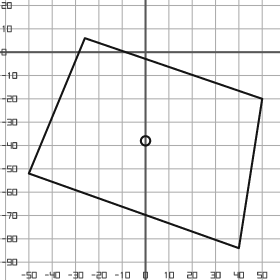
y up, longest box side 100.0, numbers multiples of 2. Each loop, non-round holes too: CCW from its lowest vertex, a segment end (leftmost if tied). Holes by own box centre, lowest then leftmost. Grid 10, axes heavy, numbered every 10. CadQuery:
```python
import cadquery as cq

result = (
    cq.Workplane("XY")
    .moveTo(40.0, -84.0)
    .lineTo(50.0, -20.0)
    .lineTo(-26.0, 6.0)
    .lineTo(-50.0, -52.0)
    .close()
    .moveTo(0.0, -38.0)
    .circle(2.0)
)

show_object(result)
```